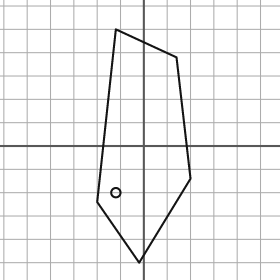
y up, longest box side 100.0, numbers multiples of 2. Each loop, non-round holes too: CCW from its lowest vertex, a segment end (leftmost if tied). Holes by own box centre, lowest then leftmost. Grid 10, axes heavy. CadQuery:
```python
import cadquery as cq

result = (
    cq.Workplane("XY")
    .moveTo(-2.0, -50.0)
    .lineTo(20.0, -14.0)
    .lineTo(14.0, 38.0)
    .lineTo(-12.0, 50.0)
    .lineTo(-20.0, -24.0)
    .close()
    .moveTo(-12.0, -20.0)
    .circle(2.0)
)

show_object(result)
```